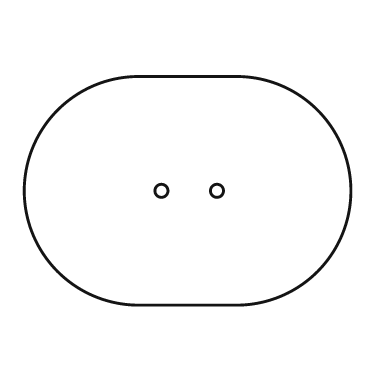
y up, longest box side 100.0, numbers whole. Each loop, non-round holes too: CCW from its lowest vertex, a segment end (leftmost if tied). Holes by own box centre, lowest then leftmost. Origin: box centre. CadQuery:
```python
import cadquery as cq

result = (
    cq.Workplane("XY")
    .moveTo(-15.0, -35.0)
    .lineTo(15.0, -35.0)
    .threePointArc((50.0, 0.0), (15.0, 35.0))
    .lineTo(-15.0, 35.0)
    .threePointArc((-50.0, 0.0), (-15.0, -35.0))
    .close()
    .moveTo(-8.0, 0.0)
    .circle(2.0)
    .moveTo(9.0, 0.0)
    .circle(2.0)
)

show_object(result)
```